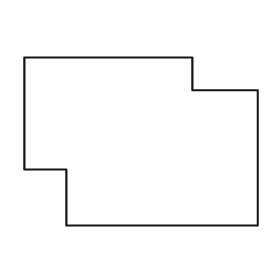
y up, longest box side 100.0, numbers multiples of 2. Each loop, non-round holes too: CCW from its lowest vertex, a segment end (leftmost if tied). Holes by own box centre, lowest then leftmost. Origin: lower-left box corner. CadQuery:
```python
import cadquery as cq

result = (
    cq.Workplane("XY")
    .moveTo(18.0, 0.0)
    .lineTo(100.0, 0.0)
    .lineTo(100.0, 58.0)
    .lineTo(72.0, 58.0)
    .lineTo(72.0, 72.0)
    .lineTo(0.0, 72.0)
    .lineTo(0.0, 24.0)
    .lineTo(18.0, 24.0)
    .close()
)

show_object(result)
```